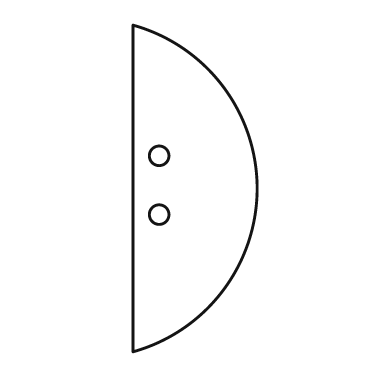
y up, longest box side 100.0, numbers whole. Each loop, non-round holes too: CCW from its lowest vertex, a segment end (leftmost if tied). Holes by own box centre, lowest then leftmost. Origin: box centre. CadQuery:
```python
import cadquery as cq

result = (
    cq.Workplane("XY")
    .moveTo(-19.0, -50.0)
    .threePointArc((19.0, 0.0), (-19.0, 50.0))
    .close()
    .moveTo(-11.0, -8.0)
    .circle(3.0)
    .moveTo(-11.0, 10.0)
    .circle(3.0)
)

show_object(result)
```